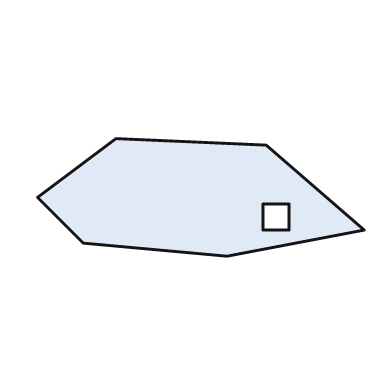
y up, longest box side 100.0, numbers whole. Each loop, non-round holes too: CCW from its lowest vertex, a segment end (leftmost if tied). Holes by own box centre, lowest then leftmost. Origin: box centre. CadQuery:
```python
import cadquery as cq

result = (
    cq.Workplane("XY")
    .moveTo(8.0, -18.0)
    .lineTo(50.0, -10.0)
    .lineTo(20.0, 16.0)
    .lineTo(-26.0, 18.0)
    .lineTo(-50.0, 0.0)
    .lineTo(-36.0, -14.0)
    .close()
    .moveTo(19.0, -10.0)
    .lineTo(27.0, -10.0)
    .lineTo(27.0, -2.0)
    .lineTo(19.0, -2.0)
    .close()
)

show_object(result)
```